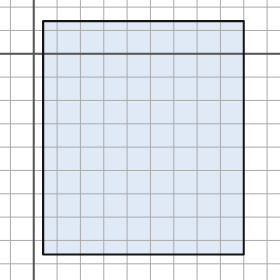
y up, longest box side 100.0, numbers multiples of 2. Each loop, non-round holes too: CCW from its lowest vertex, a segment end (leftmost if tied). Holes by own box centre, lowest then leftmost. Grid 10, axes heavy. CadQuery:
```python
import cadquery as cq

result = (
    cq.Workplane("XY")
    .moveTo(4.0, -86.0)
    .lineTo(90.0, -86.0)
    .lineTo(90.0, 14.0)
    .lineTo(4.0, 14.0)
    .close()
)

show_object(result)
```